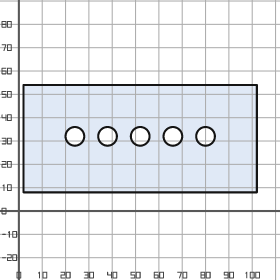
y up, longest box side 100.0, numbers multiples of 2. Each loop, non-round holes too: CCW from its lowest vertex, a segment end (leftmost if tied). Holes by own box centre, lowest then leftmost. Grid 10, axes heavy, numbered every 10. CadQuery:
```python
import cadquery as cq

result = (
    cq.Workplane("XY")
    .moveTo(2.0, 8.0)
    .lineTo(102.0, 8.0)
    .lineTo(102.0, 54.0)
    .lineTo(2.0, 54.0)
    .close()
    .moveTo(24.0, 32.0)
    .circle(4.0)
    .moveTo(38.0, 32.0)
    .circle(4.0)
    .moveTo(52.0, 32.0)
    .circle(4.0)
    .moveTo(66.0, 32.0)
    .circle(4.0)
    .moveTo(80.0, 32.0)
    .circle(4.0)
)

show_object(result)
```